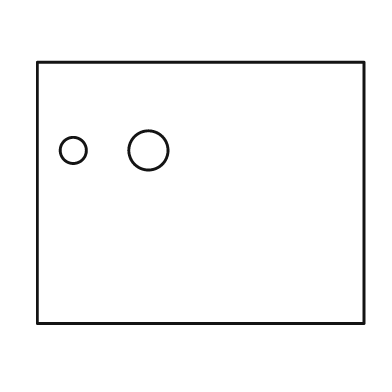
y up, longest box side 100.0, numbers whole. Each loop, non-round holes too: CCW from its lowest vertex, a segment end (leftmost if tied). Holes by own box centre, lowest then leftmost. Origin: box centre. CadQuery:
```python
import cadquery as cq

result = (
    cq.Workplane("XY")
    .moveTo(-50.0, -40.0)
    .lineTo(50.0, -40.0)
    .lineTo(50.0, 40.0)
    .lineTo(-50.0, 40.0)
    .close()
    .moveTo(-39.0, 13.0)
    .circle(4.0)
    .moveTo(-16.0, 13.0)
    .circle(6.0)
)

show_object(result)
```